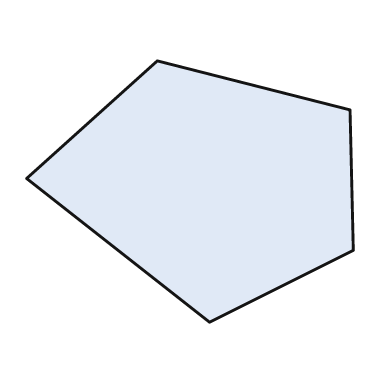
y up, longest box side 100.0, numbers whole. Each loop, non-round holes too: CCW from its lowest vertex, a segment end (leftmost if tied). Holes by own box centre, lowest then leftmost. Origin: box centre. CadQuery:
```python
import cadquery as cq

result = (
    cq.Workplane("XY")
    .moveTo(6.0, -40.0)
    .lineTo(50.0, -18.0)
    .lineTo(49.0, 25.0)
    .lineTo(-10.0, 40.0)
    .lineTo(-50.0, 4.0)
    .close()
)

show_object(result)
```